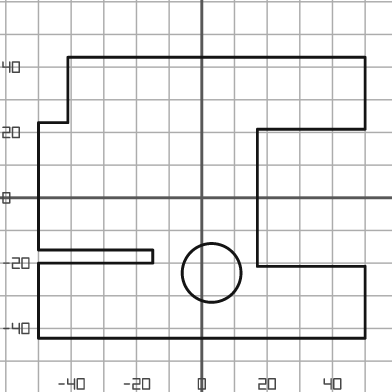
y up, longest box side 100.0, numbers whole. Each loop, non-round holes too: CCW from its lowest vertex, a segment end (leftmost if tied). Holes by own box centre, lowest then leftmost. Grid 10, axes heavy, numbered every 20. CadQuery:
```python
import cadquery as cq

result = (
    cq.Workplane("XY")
    .moveTo(-50.0, -43.0)
    .lineTo(50.0, -43.0)
    .lineTo(50.0, -21.0)
    .lineTo(17.0, -21.0)
    .lineTo(17.0, 21.0)
    .lineTo(50.0, 21.0)
    .lineTo(50.0, 43.0)
    .lineTo(-41.0, 43.0)
    .lineTo(-41.0, 23.0)
    .lineTo(-50.0, 23.0)
    .lineTo(-50.0, -16.0)
    .lineTo(-15.0, -16.0)
    .lineTo(-15.0, -20.0)
    .lineTo(-50.0, -20.0)
    .close()
    .moveTo(3.0, -23.0)
    .circle(9.0)
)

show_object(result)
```